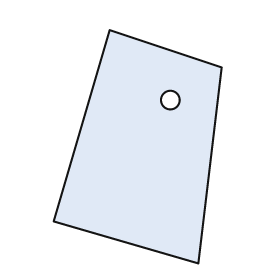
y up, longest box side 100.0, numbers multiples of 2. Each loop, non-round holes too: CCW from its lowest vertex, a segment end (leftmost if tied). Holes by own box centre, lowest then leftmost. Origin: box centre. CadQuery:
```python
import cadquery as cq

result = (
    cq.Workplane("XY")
    .moveTo(26.0, -50.0)
    .lineTo(36.0, 34.0)
    .lineTo(-12.0, 50.0)
    .lineTo(-36.0, -32.0)
    .close()
    .moveTo(14.0, 20.0)
    .circle(4.0)
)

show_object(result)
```